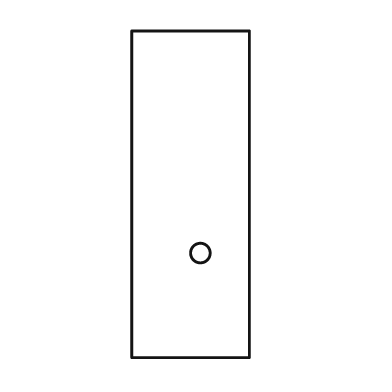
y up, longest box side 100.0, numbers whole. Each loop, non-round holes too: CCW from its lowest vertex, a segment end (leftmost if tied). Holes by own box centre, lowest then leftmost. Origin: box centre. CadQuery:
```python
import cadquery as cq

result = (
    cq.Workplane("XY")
    .moveTo(-18.0, -50.0)
    .lineTo(18.0, -50.0)
    .lineTo(18.0, 50.0)
    .lineTo(-18.0, 50.0)
    .close()
    .moveTo(3.0, -18.0)
    .circle(3.0)
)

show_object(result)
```